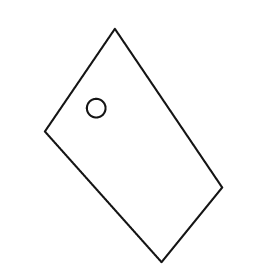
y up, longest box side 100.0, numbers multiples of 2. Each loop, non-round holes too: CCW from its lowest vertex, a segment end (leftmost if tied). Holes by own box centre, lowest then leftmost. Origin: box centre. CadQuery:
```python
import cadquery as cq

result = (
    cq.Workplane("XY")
    .moveTo(12.0, -50.0)
    .lineTo(38.0, -18.0)
    .lineTo(-8.0, 50.0)
    .lineTo(-38.0, 6.0)
    .close()
    .moveTo(-16.0, 16.0)
    .circle(4.0)
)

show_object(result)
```